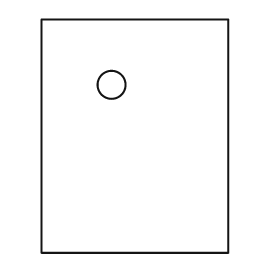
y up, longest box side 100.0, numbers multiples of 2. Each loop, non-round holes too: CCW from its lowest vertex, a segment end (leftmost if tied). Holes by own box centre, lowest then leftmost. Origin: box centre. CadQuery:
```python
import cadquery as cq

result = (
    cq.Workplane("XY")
    .moveTo(-40.0, -50.0)
    .lineTo(40.0, -50.0)
    .lineTo(40.0, 50.0)
    .lineTo(-40.0, 50.0)
    .close()
    .moveTo(-10.0, 22.0)
    .circle(6.0)
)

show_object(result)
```